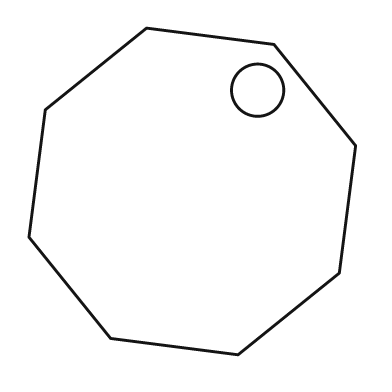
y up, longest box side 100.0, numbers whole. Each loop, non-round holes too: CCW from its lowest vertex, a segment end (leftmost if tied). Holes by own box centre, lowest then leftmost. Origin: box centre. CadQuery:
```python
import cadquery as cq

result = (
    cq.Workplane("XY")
    .moveTo(14.0, -50.0)
    .lineTo(45.0, -25.0)
    .lineTo(50.0, 14.0)
    .lineTo(25.0, 45.0)
    .lineTo(-14.0, 50.0)
    .lineTo(-45.0, 25.0)
    .lineTo(-50.0, -14.0)
    .lineTo(-25.0, -45.0)
    .close()
    .moveTo(20.0, 31.0)
    .circle(8.0)
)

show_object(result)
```